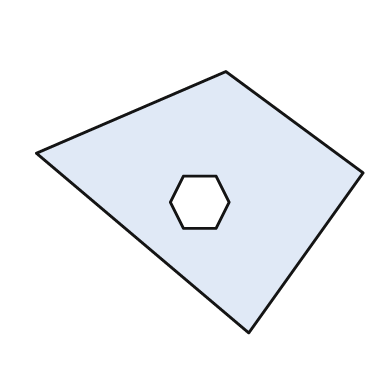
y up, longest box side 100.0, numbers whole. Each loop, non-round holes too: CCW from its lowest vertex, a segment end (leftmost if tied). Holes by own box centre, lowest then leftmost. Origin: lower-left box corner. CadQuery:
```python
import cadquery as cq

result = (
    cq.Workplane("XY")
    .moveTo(65.0, 0.0)
    .lineTo(100.0, 49.0)
    .lineTo(58.0, 80.0)
    .lineTo(0.0, 55.0)
    .close()
    .moveTo(45.0, 32.0)
    .lineTo(55.0, 32.0)
    .lineTo(59.0, 40.0)
    .lineTo(55.0, 48.0)
    .lineTo(45.0, 48.0)
    .lineTo(41.0, 40.0)
    .close()
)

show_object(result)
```